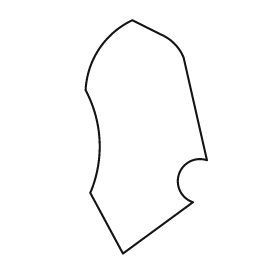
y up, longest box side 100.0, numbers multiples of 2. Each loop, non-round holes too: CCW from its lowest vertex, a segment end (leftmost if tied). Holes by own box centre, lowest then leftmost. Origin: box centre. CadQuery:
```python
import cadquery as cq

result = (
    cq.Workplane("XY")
    .moveTo(-10.0, -50.0)
    .lineTo(20.0, -28.0)
    .threePointArc((14.0, -16.0), (26.0, -10.0))
    .lineTo(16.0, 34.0)
    .threePointArc((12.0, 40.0), (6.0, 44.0))
    .lineTo(-6.0, 50.0)
    .threePointArc((-20.0, 38.0), (-26.0, 20.0))
    .threePointArc((-20.0, -2.0), (-24.0, -24.0))
    .close()
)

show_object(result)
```